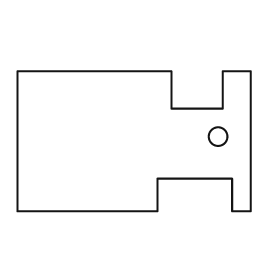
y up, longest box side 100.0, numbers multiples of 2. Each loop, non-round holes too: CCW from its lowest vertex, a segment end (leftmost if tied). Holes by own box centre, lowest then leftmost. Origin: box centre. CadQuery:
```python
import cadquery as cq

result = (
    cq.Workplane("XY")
    .moveTo(-50.0, -30.0)
    .lineTo(10.0, -30.0)
    .lineTo(10.0, -16.0)
    .lineTo(42.0, -16.0)
    .lineTo(42.0, -30.0)
    .lineTo(50.0, -30.0)
    .lineTo(50.0, 30.0)
    .lineTo(38.0, 30.0)
    .lineTo(38.0, 14.0)
    .lineTo(16.0, 14.0)
    .lineTo(16.0, 30.0)
    .lineTo(-50.0, 30.0)
    .close()
    .moveTo(36.0, 2.0)
    .circle(4.0)
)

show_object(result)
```